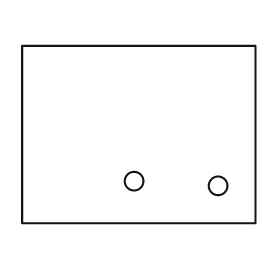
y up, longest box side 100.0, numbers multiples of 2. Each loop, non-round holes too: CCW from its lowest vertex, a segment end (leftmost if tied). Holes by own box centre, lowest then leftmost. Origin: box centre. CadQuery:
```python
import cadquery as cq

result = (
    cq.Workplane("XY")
    .moveTo(-50.0, -38.0)
    .lineTo(50.0, -38.0)
    .lineTo(50.0, 38.0)
    .lineTo(-50.0, 38.0)
    .close()
    .moveTo(34.0, -22.0)
    .circle(4.0)
    .moveTo(-2.0, -20.0)
    .circle(4.0)
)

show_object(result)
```